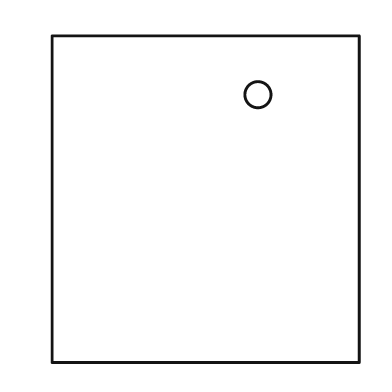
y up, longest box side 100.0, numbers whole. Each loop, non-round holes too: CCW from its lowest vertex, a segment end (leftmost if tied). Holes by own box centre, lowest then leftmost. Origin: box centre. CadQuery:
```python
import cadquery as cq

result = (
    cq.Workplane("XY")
    .moveTo(-47.0, -50.0)
    .lineTo(47.0, -50.0)
    .lineTo(47.0, 50.0)
    .lineTo(-47.0, 50.0)
    .close()
    .moveTo(16.0, 32.0)
    .circle(4.0)
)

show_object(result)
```